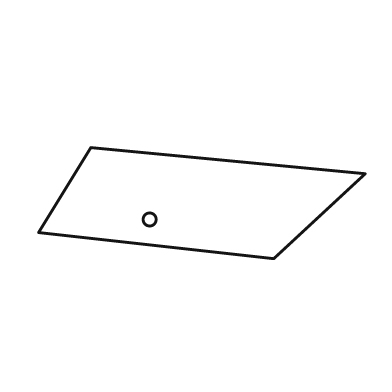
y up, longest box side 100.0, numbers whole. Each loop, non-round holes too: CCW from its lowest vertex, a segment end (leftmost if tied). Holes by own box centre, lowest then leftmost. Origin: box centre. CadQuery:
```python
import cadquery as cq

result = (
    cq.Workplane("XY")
    .moveTo(22.0, -17.0)
    .lineTo(50.0, 9.0)
    .lineTo(-34.0, 17.0)
    .lineTo(-50.0, -9.0)
    .close()
    .moveTo(-16.0, -5.0)
    .circle(2.0)
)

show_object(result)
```